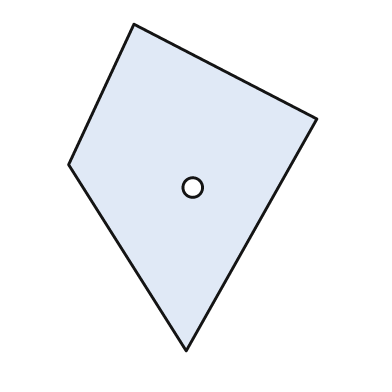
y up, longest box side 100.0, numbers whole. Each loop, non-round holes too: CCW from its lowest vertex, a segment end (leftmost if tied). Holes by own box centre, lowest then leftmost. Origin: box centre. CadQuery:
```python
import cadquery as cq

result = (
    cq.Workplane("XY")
    .moveTo(-2.0, -50.0)
    .lineTo(38.0, 21.0)
    .lineTo(-18.0, 50.0)
    .lineTo(-38.0, 7.0)
    .close()
    .moveTo(0.0, 0.0)
    .circle(3.0)
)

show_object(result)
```